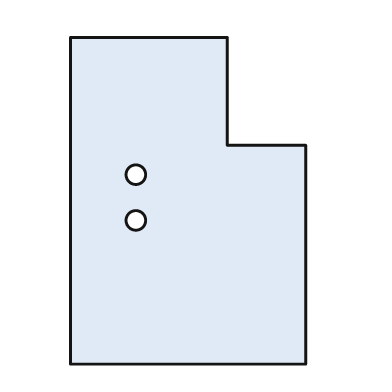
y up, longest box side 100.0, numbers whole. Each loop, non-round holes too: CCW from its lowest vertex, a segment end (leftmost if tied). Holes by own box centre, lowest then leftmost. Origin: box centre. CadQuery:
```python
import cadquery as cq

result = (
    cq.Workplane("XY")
    .moveTo(-36.0, -50.0)
    .lineTo(36.0, -50.0)
    .lineTo(36.0, 17.0)
    .lineTo(12.0, 17.0)
    .lineTo(12.0, 50.0)
    .lineTo(-36.0, 50.0)
    .close()
    .moveTo(-16.0, -6.0)
    .circle(3.0)
    .moveTo(-16.0, 8.0)
    .circle(3.0)
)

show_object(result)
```